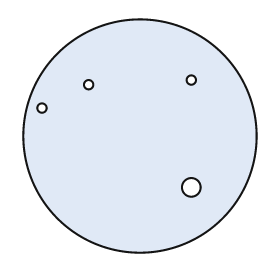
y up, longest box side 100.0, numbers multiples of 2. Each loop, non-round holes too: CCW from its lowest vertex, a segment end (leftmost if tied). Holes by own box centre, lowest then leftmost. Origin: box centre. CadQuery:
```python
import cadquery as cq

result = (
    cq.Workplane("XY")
    .moveTo(0.0, 0.0)
    .circle(50.0)
    .moveTo(22.0, -22.0)
    .circle(4.0)
    .moveTo(-42.0, 12.0)
    .circle(2.0)
    .moveTo(-22.0, 22.0)
    .circle(2.0)
    .moveTo(22.0, 24.0)
    .circle(2.0)
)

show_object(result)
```